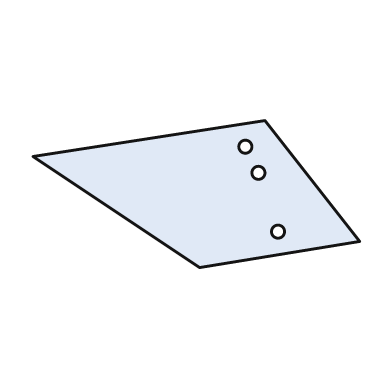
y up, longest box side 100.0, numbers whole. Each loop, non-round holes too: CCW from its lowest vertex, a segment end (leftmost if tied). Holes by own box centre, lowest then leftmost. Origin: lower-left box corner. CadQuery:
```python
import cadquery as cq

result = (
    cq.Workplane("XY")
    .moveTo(51.0, 0.0)
    .lineTo(100.0, 8.0)
    .lineTo(71.0, 45.0)
    .lineTo(0.0, 34.0)
    .close()
    .moveTo(75.0, 11.0)
    .circle(2.0)
    .moveTo(69.0, 29.0)
    .circle(2.0)
    .moveTo(65.0, 37.0)
    .circle(2.0)
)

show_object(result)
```